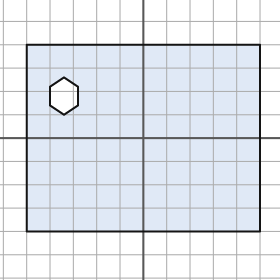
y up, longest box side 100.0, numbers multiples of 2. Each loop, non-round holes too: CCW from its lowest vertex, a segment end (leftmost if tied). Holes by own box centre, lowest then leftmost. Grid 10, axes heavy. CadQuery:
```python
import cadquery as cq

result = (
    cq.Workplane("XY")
    .moveTo(-50.0, -40.0)
    .lineTo(50.0, -40.0)
    .lineTo(50.0, 40.0)
    .lineTo(-50.0, 40.0)
    .close()
    .moveTo(-34.0, 10.0)
    .lineTo(-28.0, 14.0)
    .lineTo(-28.0, 22.0)
    .lineTo(-34.0, 26.0)
    .lineTo(-40.0, 22.0)
    .lineTo(-40.0, 14.0)
    .close()
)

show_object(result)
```